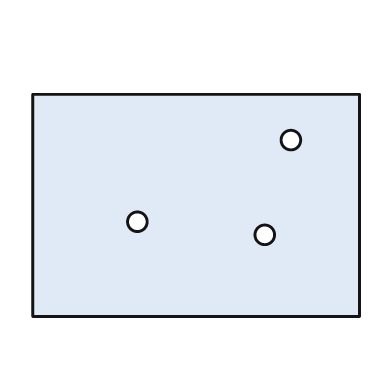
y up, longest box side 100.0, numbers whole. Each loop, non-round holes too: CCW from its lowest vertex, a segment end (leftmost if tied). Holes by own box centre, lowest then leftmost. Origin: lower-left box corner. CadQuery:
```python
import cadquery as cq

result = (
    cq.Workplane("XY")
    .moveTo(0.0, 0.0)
    .lineTo(100.0, 0.0)
    .lineTo(100.0, 68.0)
    .lineTo(0.0, 68.0)
    .close()
    .moveTo(71.0, 25.0)
    .circle(3.0)
    .moveTo(32.0, 29.0)
    .circle(3.0)
    .moveTo(79.0, 54.0)
    .circle(3.0)
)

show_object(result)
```